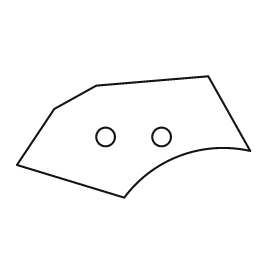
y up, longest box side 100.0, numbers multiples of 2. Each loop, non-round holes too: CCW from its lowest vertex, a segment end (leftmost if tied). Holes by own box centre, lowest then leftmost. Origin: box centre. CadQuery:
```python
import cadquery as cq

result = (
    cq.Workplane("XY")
    .moveTo(-4.0, -26.0)
    .threePointArc((20.0, -8.0), (50.0, -6.0))
    .lineTo(32.0, 26.0)
    .lineTo(-16.0, 22.0)
    .lineTo(-34.0, 12.0)
    .lineTo(-50.0, -12.0)
    .close()
    .moveTo(-12.0, 0.0)
    .circle(4.0)
    .moveTo(12.0, 0.0)
    .circle(4.0)
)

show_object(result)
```